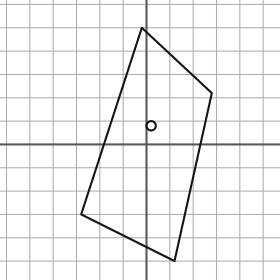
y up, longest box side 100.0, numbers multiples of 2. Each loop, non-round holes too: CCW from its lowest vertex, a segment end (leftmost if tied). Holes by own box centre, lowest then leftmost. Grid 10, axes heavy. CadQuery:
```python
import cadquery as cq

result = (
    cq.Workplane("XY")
    .moveTo(12.0, -50.0)
    .lineTo(28.0, 22.0)
    .lineTo(-2.0, 50.0)
    .lineTo(-28.0, -30.0)
    .close()
    .moveTo(2.0, 8.0)
    .circle(2.0)
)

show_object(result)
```